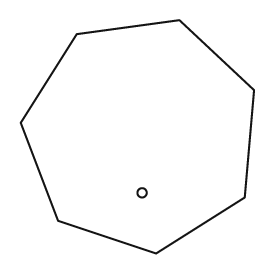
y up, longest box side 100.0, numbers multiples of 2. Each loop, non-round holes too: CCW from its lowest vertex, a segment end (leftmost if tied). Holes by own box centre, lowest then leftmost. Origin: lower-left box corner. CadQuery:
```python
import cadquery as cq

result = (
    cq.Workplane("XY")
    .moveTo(58.0, 0.0)
    .lineTo(96.0, 24.0)
    .lineTo(100.0, 70.0)
    .lineTo(68.0, 100.0)
    .lineTo(24.0, 94.0)
    .lineTo(0.0, 56.0)
    .lineTo(16.0, 14.0)
    .close()
    .moveTo(52.0, 26.0)
    .circle(2.0)
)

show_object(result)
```